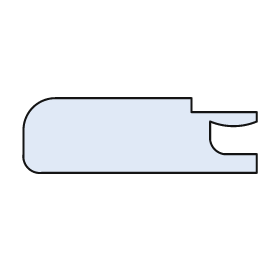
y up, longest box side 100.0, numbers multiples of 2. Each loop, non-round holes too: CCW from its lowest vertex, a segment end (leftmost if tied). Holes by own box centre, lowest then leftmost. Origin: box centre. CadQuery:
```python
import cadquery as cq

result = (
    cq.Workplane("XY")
    .moveTo(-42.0, -16.0)
    .lineTo(50.0, -16.0)
    .lineTo(50.0, -8.0)
    .lineTo(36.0, -8.0)
    .threePointArc((32.0, -6.0), (30.0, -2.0))
    .lineTo(30.0, 6.0)
    .threePointArc((40.0, 4.0), (50.0, 6.0))
    .lineTo(50.0, 10.0)
    .lineTo(22.0, 10.0)
    .lineTo(22.0, 16.0)
    .lineTo(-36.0, 16.0)
    .threePointArc((-46.0, 12.0), (-50.0, 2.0))
    .lineTo(-50.0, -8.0)
    .threePointArc((-48.0, -14.0), (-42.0, -16.0))
    .close()
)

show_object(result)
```